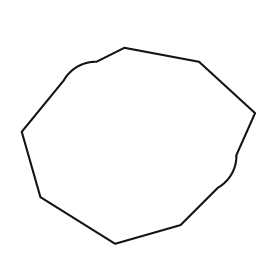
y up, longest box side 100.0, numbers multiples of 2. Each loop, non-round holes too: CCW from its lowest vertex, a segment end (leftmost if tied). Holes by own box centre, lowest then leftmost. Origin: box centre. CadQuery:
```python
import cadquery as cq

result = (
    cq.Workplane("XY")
    .moveTo(-10.0, -42.0)
    .lineTo(18.0, -34.0)
    .lineTo(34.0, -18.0)
    .threePointArc((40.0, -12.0), (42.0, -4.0))
    .lineTo(50.0, 14.0)
    .lineTo(26.0, 36.0)
    .lineTo(-6.0, 42.0)
    .lineTo(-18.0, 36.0)
    .threePointArc((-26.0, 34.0), (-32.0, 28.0))
    .lineTo(-50.0, 6.0)
    .lineTo(-42.0, -22.0)
    .close()
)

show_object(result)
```